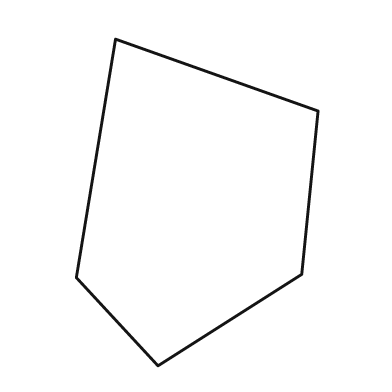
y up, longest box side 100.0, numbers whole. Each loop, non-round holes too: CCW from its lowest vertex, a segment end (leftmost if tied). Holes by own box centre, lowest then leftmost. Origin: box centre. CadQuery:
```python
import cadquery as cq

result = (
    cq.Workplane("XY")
    .moveTo(-12.0, -50.0)
    .lineTo(32.0, -22.0)
    .lineTo(37.0, 28.0)
    .lineTo(-25.0, 50.0)
    .lineTo(-37.0, -23.0)
    .close()
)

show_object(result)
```